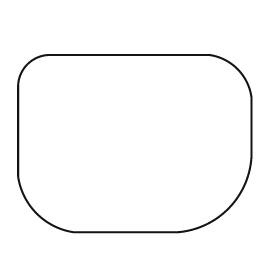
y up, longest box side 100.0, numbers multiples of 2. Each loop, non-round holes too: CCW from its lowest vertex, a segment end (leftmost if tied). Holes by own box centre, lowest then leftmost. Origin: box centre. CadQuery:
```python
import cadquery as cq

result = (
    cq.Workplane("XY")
    .moveTo(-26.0, -38.0)
    .lineTo(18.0, -38.0)
    .threePointArc((40.0, -28.0), (50.0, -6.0))
    .lineTo(50.0, 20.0)
    .threePointArc((44.0, 32.0), (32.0, 38.0))
    .lineTo(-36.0, 38.0)
    .threePointArc((-46.0, 34.0), (-50.0, 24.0))
    .lineTo(-50.0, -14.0)
    .threePointArc((-42.0, -30.0), (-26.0, -38.0))
    .close()
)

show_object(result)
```